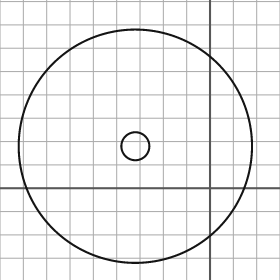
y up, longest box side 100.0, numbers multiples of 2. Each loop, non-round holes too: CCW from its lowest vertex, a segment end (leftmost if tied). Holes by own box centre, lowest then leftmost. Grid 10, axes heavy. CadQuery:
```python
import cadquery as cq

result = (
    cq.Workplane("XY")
    .moveTo(-32.0, 18.0)
    .circle(50.0)
    .moveTo(-32.0, 18.0)
    .circle(6.0)
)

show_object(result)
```